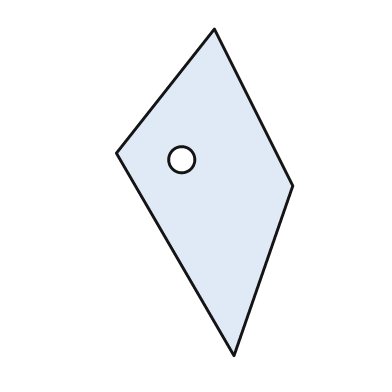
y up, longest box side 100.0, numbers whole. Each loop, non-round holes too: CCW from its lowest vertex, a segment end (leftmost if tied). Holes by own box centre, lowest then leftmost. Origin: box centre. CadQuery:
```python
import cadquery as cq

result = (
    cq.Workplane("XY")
    .moveTo(9.0, -50.0)
    .lineTo(27.0, 2.0)
    .lineTo(3.0, 50.0)
    .lineTo(-27.0, 12.0)
    .close()
    .moveTo(-7.0, 10.0)
    .circle(4.0)
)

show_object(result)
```